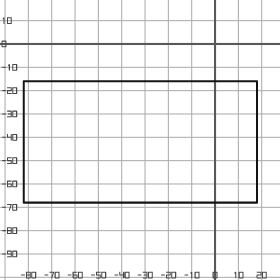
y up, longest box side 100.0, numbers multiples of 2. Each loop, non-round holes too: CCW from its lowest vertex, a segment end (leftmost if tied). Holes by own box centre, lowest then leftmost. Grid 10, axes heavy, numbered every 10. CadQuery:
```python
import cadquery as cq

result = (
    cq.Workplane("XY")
    .moveTo(-82.0, -68.0)
    .lineTo(18.0, -68.0)
    .lineTo(18.0, -16.0)
    .lineTo(-82.0, -16.0)
    .close()
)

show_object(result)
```